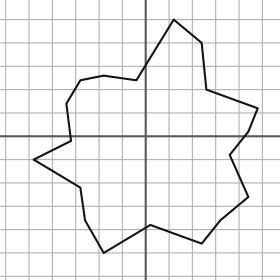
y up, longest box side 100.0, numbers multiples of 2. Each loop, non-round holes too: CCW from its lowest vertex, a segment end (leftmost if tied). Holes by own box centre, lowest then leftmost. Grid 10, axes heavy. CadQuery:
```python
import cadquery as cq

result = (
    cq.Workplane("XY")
    .moveTo(-18.0, -50.0)
    .lineTo(2.0, -38.0)
    .lineTo(24.0, -46.0)
    .lineTo(32.0, -36.0)
    .lineTo(44.0, -26.0)
    .lineTo(36.0, -8.0)
    .lineTo(44.0, 2.0)
    .lineTo(48.0, 12.0)
    .lineTo(26.0, 20.0)
    .lineTo(24.0, 40.0)
    .lineTo(12.0, 50.0)
    .lineTo(-4.0, 24.0)
    .lineTo(-18.0, 26.0)
    .lineTo(-28.0, 24.0)
    .lineTo(-34.0, 14.0)
    .lineTo(-32.0, -2.0)
    .lineTo(-48.0, -10.0)
    .lineTo(-28.0, -22.0)
    .lineTo(-26.0, -36.0)
    .close()
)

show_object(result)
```